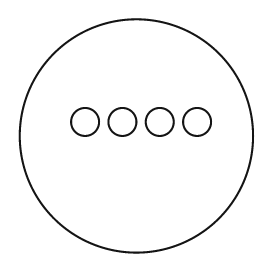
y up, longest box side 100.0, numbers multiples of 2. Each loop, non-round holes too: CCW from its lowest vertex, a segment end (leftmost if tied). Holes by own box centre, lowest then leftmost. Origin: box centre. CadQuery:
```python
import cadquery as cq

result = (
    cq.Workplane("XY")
    .moveTo(0.0, 0.0)
    .circle(50.0)
    .moveTo(-22.0, 6.0)
    .circle(6.0)
    .moveTo(-6.0, 6.0)
    .circle(6.0)
    .moveTo(10.0, 6.0)
    .circle(6.0)
    .moveTo(26.0, 6.0)
    .circle(6.0)
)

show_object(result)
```